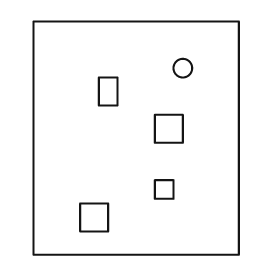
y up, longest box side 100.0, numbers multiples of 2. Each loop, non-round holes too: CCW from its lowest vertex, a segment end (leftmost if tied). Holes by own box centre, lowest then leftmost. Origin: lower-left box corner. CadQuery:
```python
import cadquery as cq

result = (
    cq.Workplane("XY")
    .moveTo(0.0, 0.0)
    .lineTo(88.0, 0.0)
    .lineTo(88.0, 100.0)
    .lineTo(0.0, 100.0)
    .close()
    .moveTo(20.0, 10.0)
    .lineTo(32.0, 10.0)
    .lineTo(32.0, 22.0)
    .lineTo(20.0, 22.0)
    .close()
    .moveTo(52.0, 24.0)
    .lineTo(60.0, 24.0)
    .lineTo(60.0, 32.0)
    .lineTo(52.0, 32.0)
    .close()
    .moveTo(52.0, 48.0)
    .lineTo(64.0, 48.0)
    .lineTo(64.0, 60.0)
    .lineTo(52.0, 60.0)
    .close()
    .moveTo(28.0, 64.0)
    .lineTo(36.0, 64.0)
    .lineTo(36.0, 76.0)
    .lineTo(28.0, 76.0)
    .close()
    .moveTo(64.0, 80.0)
    .circle(4.0)
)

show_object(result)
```